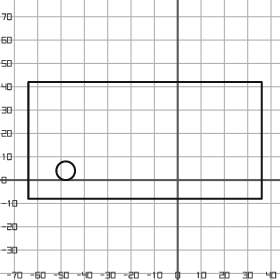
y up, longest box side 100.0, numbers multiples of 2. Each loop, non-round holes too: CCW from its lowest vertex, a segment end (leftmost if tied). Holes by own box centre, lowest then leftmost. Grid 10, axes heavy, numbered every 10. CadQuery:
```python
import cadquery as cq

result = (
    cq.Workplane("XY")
    .moveTo(-64.0, -8.0)
    .lineTo(36.0, -8.0)
    .lineTo(36.0, 42.0)
    .lineTo(-64.0, 42.0)
    .close()
    .moveTo(-48.0, 4.0)
    .circle(4.0)
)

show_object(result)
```